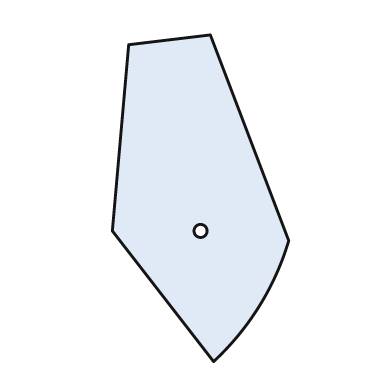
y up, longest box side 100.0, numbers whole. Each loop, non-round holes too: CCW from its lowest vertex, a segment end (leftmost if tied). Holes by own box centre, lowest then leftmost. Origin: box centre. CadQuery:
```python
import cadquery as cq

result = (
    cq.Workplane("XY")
    .moveTo(4.0, -50.0)
    .threePointArc((18.0, -33.0), (27.0, -13.0))
    .lineTo(3.0, 50.0)
    .lineTo(-22.0, 47.0)
    .lineTo(-27.0, -10.0)
    .close()
    .moveTo(0.0, -10.0)
    .circle(2.0)
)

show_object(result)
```